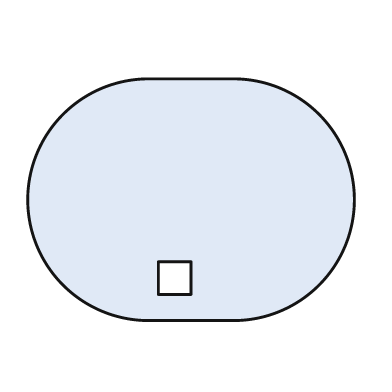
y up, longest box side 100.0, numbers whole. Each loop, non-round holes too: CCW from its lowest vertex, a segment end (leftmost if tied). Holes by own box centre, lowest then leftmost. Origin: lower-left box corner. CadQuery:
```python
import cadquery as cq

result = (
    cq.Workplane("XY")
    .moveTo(37.0, 0.0)
    .lineTo(63.0, 0.0)
    .threePointArc((100.0, 37.0), (63.0, 74.0))
    .lineTo(37.0, 74.0)
    .threePointArc((0.0, 37.0), (37.0, 0.0))
    .close()
    .moveTo(40.0, 8.0)
    .lineTo(50.0, 8.0)
    .lineTo(50.0, 18.0)
    .lineTo(40.0, 18.0)
    .close()
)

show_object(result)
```